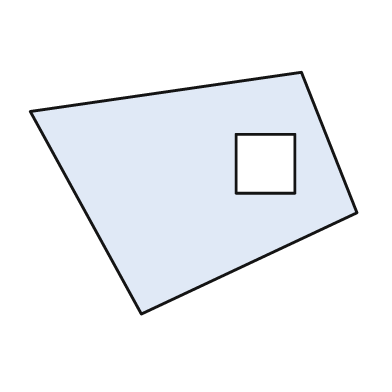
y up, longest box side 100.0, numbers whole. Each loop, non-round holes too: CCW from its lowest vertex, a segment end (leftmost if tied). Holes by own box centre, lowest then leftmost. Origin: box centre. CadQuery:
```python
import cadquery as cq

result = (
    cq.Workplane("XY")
    .moveTo(-16.0, -37.0)
    .lineTo(50.0, -6.0)
    .lineTo(33.0, 37.0)
    .lineTo(-50.0, 25.0)
    .close()
    .moveTo(13.0, 0.0)
    .lineTo(31.0, 0.0)
    .lineTo(31.0, 18.0)
    .lineTo(13.0, 18.0)
    .close()
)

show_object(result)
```